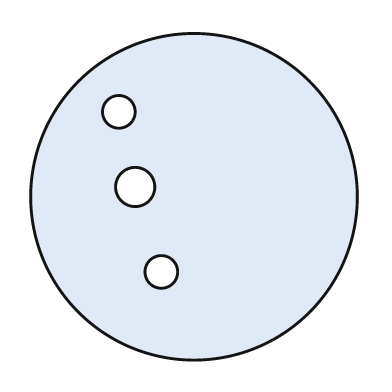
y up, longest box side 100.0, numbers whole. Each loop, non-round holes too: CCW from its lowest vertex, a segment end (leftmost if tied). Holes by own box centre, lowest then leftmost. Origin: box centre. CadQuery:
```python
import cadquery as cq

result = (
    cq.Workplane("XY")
    .moveTo(0.0, 0.0)
    .circle(50.0)
    .moveTo(-10.0, -23.0)
    .circle(5.0)
    .moveTo(-18.0, 3.0)
    .circle(6.0)
    .moveTo(-23.0, 26.0)
    .circle(5.0)
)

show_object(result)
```